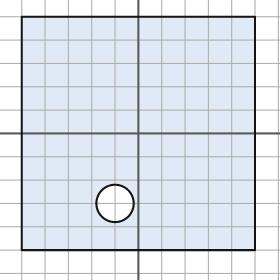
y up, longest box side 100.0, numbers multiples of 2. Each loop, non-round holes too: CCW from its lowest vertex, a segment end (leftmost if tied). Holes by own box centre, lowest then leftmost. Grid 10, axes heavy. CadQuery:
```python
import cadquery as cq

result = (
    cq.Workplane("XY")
    .moveTo(-50.0, -50.0)
    .lineTo(50.0, -50.0)
    .lineTo(50.0, 50.0)
    .lineTo(-50.0, 50.0)
    .close()
    .moveTo(-10.0, -30.0)
    .circle(8.0)
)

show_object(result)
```